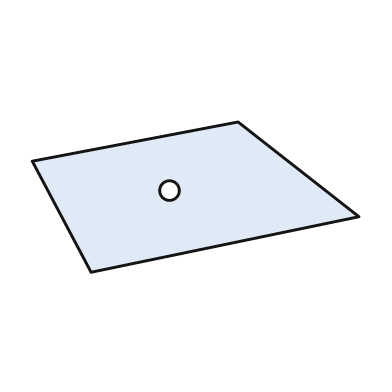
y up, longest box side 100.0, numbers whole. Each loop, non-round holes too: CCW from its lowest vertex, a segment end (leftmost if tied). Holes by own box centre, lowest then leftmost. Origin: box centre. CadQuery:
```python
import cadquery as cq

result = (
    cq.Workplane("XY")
    .moveTo(-32.0, -23.0)
    .lineTo(50.0, -6.0)
    .lineTo(13.0, 23.0)
    .lineTo(-50.0, 11.0)
    .close()
    .moveTo(-8.0, 2.0)
    .circle(3.0)
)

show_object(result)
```